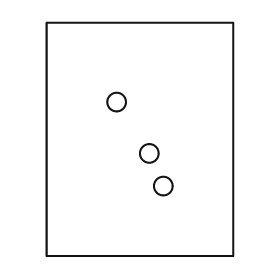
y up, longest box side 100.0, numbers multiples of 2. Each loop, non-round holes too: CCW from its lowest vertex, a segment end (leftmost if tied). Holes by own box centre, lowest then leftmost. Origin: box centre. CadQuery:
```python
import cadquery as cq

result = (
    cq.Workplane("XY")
    .moveTo(-40.0, -50.0)
    .lineTo(40.0, -50.0)
    .lineTo(40.0, 50.0)
    .lineTo(-40.0, 50.0)
    .close()
    .moveTo(10.0, -20.0)
    .circle(4.0)
    .moveTo(4.0, -6.0)
    .circle(4.0)
    .moveTo(-10.0, 16.0)
    .circle(4.0)
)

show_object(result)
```